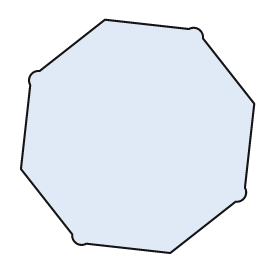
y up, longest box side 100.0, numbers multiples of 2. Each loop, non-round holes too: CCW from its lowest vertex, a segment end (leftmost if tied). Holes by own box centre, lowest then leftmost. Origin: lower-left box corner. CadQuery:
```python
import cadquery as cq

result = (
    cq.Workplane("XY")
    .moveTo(64.0, 0.0)
    .lineTo(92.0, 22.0)
    .threePointArc((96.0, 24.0), (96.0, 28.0))
    .lineTo(100.0, 64.0)
    .lineTo(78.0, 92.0)
    .threePointArc((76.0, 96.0), (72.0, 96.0))
    .lineTo(36.0, 100.0)
    .lineTo(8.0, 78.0)
    .threePointArc((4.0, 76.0), (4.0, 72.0))
    .lineTo(0.0, 36.0)
    .lineTo(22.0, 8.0)
    .threePointArc((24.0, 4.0), (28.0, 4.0))
    .close()
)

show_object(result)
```